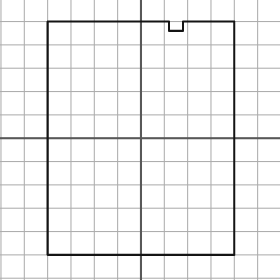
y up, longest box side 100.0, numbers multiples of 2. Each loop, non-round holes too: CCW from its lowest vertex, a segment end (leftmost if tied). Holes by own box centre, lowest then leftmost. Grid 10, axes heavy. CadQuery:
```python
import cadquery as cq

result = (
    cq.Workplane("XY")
    .moveTo(-40.0, -50.0)
    .lineTo(40.0, -50.0)
    .lineTo(40.0, 50.0)
    .lineTo(18.0, 50.0)
    .lineTo(18.0, 46.0)
    .lineTo(12.0, 46.0)
    .lineTo(12.0, 50.0)
    .lineTo(-40.0, 50.0)
    .close()
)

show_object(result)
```